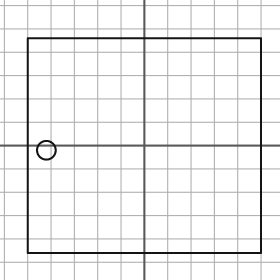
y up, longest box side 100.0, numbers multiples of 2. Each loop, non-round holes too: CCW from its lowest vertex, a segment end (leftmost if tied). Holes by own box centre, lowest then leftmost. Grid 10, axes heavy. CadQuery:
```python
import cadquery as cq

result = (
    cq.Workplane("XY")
    .moveTo(-50.0, -46.0)
    .lineTo(50.0, -46.0)
    .lineTo(50.0, 46.0)
    .lineTo(-50.0, 46.0)
    .close()
    .moveTo(-42.0, -2.0)
    .circle(4.0)
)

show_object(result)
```